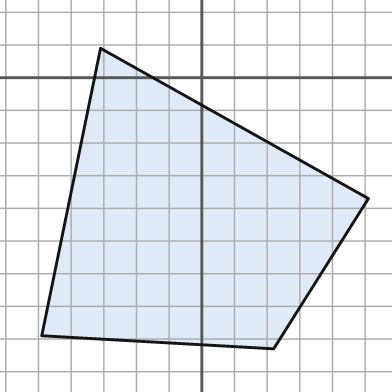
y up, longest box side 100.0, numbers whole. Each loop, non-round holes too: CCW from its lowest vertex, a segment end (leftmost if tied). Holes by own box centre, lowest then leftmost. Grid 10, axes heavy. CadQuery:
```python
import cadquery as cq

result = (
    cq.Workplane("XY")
    .moveTo(22.0, -83.0)
    .lineTo(51.0, -37.0)
    .lineTo(-31.0, 9.0)
    .lineTo(-49.0, -79.0)
    .close()
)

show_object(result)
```